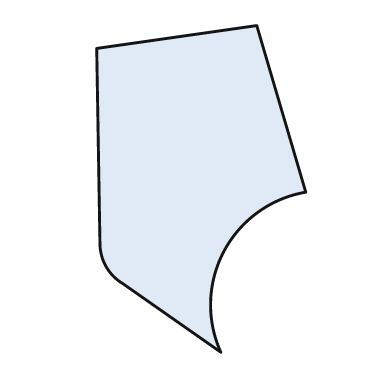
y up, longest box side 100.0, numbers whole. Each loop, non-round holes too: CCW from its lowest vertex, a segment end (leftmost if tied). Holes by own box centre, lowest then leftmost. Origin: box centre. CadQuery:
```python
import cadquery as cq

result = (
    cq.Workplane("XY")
    .moveTo(6.0, -50.0)
    .threePointArc((7.0, -19.0), (32.0, -1.0))
    .lineTo(17.0, 50.0)
    .lineTo(-32.0, 43.0)
    .lineTo(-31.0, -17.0)
    .threePointArc((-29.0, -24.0), (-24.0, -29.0))
    .close()
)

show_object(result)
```